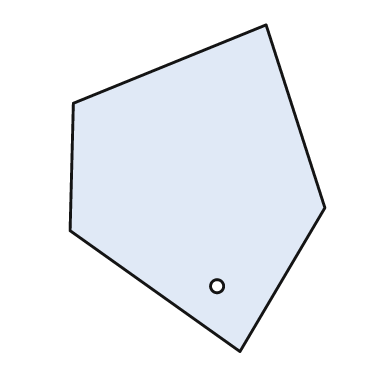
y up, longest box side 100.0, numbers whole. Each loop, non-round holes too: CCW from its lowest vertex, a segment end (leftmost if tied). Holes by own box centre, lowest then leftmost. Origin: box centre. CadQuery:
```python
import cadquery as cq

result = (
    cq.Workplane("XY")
    .moveTo(13.0, -50.0)
    .lineTo(39.0, -6.0)
    .lineTo(21.0, 50.0)
    .lineTo(-38.0, 26.0)
    .lineTo(-39.0, -13.0)
    .close()
    .moveTo(6.0, -30.0)
    .circle(2.0)
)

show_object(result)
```